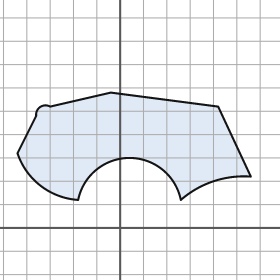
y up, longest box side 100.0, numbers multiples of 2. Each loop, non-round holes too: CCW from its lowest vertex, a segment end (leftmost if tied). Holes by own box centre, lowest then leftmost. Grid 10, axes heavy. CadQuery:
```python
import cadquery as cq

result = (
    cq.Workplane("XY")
    .moveTo(-18.0, 12.0)
    .threePointArc((4.0, 30.0), (26.0, 12.0))
    .threePointArc((40.0, 20.0), (56.0, 22.0))
    .lineTo(42.0, 52.0)
    .lineTo(-4.0, 58.0)
    .lineTo(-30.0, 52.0)
    .threePointArc((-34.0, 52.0), (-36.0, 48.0))
    .lineTo(-44.0, 32.0)
    .threePointArc((-34.0, 18.0), (-18.0, 12.0))
    .close()
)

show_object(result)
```